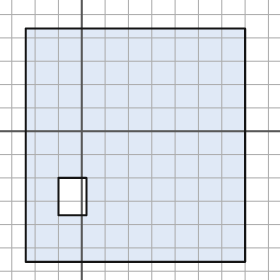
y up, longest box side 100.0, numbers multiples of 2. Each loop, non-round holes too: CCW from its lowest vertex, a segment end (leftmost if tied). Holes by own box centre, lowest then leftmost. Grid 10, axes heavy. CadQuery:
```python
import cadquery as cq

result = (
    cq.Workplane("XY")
    .moveTo(-24.0, -56.0)
    .lineTo(70.0, -56.0)
    .lineTo(70.0, 44.0)
    .lineTo(-24.0, 44.0)
    .close()
    .moveTo(-10.0, -36.0)
    .lineTo(2.0, -36.0)
    .lineTo(2.0, -20.0)
    .lineTo(-10.0, -20.0)
    .close()
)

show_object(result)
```